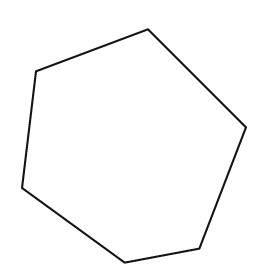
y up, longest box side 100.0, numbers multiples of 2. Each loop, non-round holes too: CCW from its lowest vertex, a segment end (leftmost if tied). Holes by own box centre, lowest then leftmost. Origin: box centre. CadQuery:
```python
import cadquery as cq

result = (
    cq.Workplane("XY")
    .moveTo(-4.0, -50.0)
    .lineTo(28.0, -44.0)
    .lineTo(48.0, 8.0)
    .lineTo(6.0, 50.0)
    .lineTo(-42.0, 32.0)
    .lineTo(-48.0, -18.0)
    .close()
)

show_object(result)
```